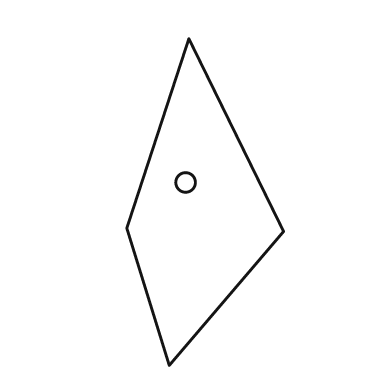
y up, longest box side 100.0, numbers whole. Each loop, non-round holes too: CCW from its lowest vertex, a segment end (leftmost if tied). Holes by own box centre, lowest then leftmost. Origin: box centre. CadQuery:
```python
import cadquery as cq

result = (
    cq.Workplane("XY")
    .moveTo(-11.0, -50.0)
    .lineTo(24.0, -9.0)
    .lineTo(-5.0, 50.0)
    .lineTo(-24.0, -8.0)
    .close()
    .moveTo(-6.0, 6.0)
    .circle(3.0)
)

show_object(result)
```